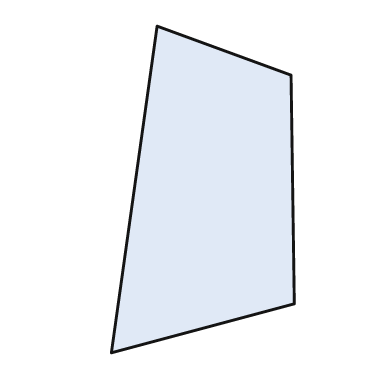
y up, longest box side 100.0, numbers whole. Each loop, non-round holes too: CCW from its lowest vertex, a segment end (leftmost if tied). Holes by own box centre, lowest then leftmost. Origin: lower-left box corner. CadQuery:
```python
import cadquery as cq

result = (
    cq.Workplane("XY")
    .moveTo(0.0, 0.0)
    .lineTo(56.0, 15.0)
    .lineTo(55.0, 85.0)
    .lineTo(14.0, 100.0)
    .close()
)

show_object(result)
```